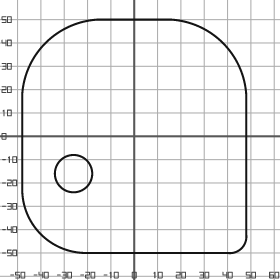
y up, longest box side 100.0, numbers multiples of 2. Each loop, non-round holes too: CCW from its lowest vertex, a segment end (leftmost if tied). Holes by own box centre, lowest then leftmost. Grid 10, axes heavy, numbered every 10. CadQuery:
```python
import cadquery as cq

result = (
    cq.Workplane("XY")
    .moveTo(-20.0, -50.0)
    .lineTo(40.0, -50.0)
    .threePointArc((46.0, -48.0), (48.0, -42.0))
    .lineTo(48.0, 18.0)
    .threePointArc((38.0, 40.0), (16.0, 50.0))
    .lineTo(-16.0, 50.0)
    .threePointArc((-38.0, 40.0), (-48.0, 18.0))
    .lineTo(-48.0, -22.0)
    .threePointArc((-40.0, -42.0), (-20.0, -50.0))
    .close()
    .moveTo(-26.0, -16.0)
    .circle(8.0)
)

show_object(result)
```